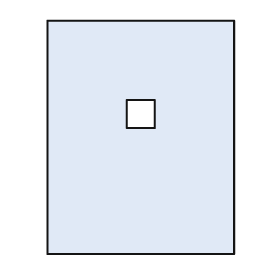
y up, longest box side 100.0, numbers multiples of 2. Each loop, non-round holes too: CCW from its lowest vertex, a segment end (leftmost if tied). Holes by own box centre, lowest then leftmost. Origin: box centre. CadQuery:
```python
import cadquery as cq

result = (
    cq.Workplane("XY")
    .moveTo(-40.0, -50.0)
    .lineTo(40.0, -50.0)
    .lineTo(40.0, 50.0)
    .lineTo(-40.0, 50.0)
    .close()
    .moveTo(-6.0, 4.0)
    .lineTo(6.0, 4.0)
    .lineTo(6.0, 16.0)
    .lineTo(-6.0, 16.0)
    .close()
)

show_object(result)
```